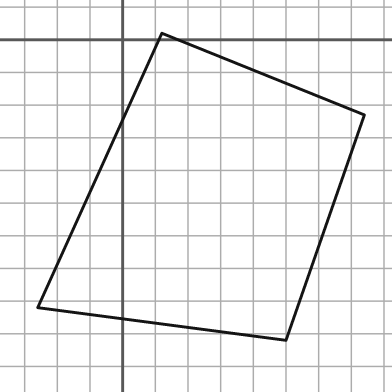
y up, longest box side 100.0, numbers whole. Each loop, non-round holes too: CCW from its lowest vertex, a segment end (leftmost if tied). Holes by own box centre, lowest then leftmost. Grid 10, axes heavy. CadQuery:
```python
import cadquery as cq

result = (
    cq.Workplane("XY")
    .moveTo(50.0, -92.0)
    .lineTo(74.0, -23.0)
    .lineTo(12.0, 2.0)
    .lineTo(-26.0, -82.0)
    .close()
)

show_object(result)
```